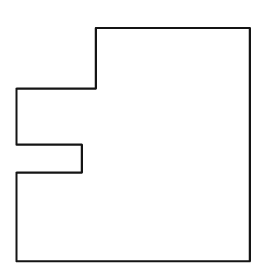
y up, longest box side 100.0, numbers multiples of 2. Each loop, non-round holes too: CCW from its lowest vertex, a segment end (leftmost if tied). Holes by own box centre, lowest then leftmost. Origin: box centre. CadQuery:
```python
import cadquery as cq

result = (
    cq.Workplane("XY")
    .moveTo(-50.0, -50.0)
    .lineTo(50.0, -50.0)
    .lineTo(50.0, 50.0)
    .lineTo(-16.0, 50.0)
    .lineTo(-16.0, 24.0)
    .lineTo(-50.0, 24.0)
    .lineTo(-50.0, 0.0)
    .lineTo(-22.0, 0.0)
    .lineTo(-22.0, -12.0)
    .lineTo(-50.0, -12.0)
    .close()
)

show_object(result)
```